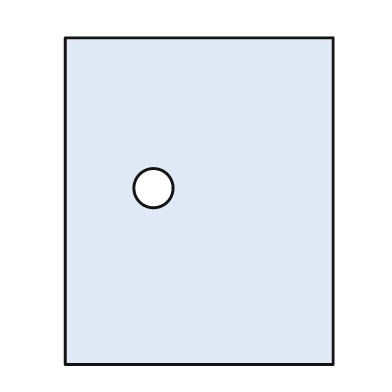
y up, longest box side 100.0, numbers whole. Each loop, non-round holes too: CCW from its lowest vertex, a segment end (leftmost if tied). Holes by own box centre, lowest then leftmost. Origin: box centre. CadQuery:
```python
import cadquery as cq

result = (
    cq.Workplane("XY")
    .moveTo(-41.0, -50.0)
    .lineTo(41.0, -50.0)
    .lineTo(41.0, 50.0)
    .lineTo(-41.0, 50.0)
    .close()
    .moveTo(-14.0, 4.0)
    .circle(6.0)
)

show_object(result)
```